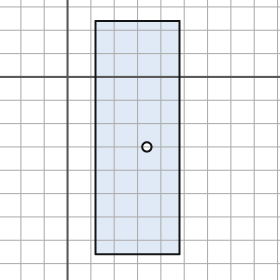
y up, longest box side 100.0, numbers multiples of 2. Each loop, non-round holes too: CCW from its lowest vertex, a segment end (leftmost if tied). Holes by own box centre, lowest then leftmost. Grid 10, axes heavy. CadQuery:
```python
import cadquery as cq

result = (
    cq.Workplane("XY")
    .moveTo(12.0, -76.0)
    .lineTo(48.0, -76.0)
    .lineTo(48.0, 24.0)
    .lineTo(12.0, 24.0)
    .close()
    .moveTo(34.0, -30.0)
    .circle(2.0)
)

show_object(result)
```